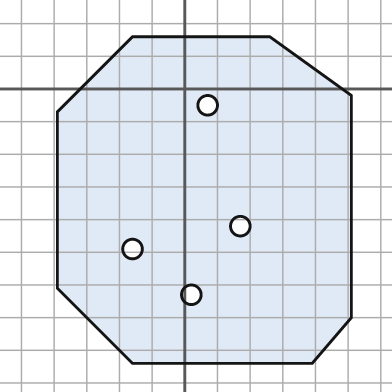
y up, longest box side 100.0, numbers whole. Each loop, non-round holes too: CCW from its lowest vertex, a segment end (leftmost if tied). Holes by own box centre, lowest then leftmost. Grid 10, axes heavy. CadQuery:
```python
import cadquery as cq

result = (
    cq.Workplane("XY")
    .moveTo(-16.0, -84.0)
    .lineTo(39.0, -84.0)
    .lineTo(51.0, -70.0)
    .lineTo(51.0, -2.0)
    .lineTo(26.0, 16.0)
    .lineTo(-16.0, 16.0)
    .lineTo(-39.0, -7.0)
    .lineTo(-39.0, -61.0)
    .close()
    .moveTo(2.0, -63.0)
    .circle(3.0)
    .moveTo(-16.0, -49.0)
    .circle(3.0)
    .moveTo(17.0, -42.0)
    .circle(3.0)
    .moveTo(7.0, -5.0)
    .circle(3.0)
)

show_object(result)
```